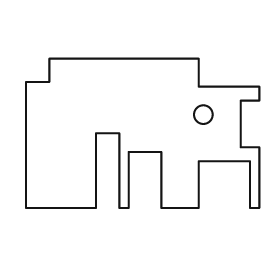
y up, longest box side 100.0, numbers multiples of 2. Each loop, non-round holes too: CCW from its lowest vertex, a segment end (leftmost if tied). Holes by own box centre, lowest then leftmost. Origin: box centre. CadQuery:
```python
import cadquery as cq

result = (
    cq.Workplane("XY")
    .moveTo(-50.0, -32.0)
    .lineTo(-20.0, -32.0)
    .lineTo(-20.0, 0.0)
    .lineTo(-10.0, 0.0)
    .lineTo(-10.0, -32.0)
    .lineTo(-6.0, -32.0)
    .lineTo(-6.0, -8.0)
    .lineTo(8.0, -8.0)
    .lineTo(8.0, -32.0)
    .lineTo(24.0, -32.0)
    .lineTo(24.0, -12.0)
    .lineTo(46.0, -12.0)
    .lineTo(46.0, -32.0)
    .lineTo(50.0, -32.0)
    .lineTo(50.0, -6.0)
    .lineTo(42.0, -6.0)
    .lineTo(42.0, 14.0)
    .lineTo(50.0, 14.0)
    .lineTo(50.0, 20.0)
    .lineTo(24.0, 20.0)
    .lineTo(24.0, 32.0)
    .lineTo(-40.0, 32.0)
    .lineTo(-40.0, 22.0)
    .lineTo(-50.0, 22.0)
    .close()
    .moveTo(26.0, 8.0)
    .circle(4.0)
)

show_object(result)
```